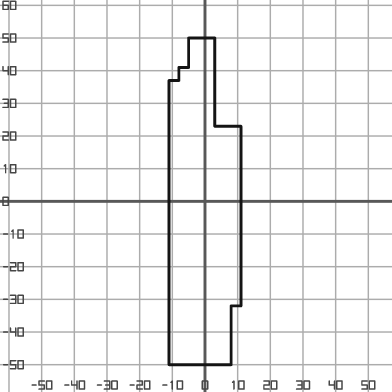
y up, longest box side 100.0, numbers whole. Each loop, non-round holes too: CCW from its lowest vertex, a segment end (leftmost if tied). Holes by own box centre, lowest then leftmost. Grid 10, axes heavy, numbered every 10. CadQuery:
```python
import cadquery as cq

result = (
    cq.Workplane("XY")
    .moveTo(-11.0, -50.0)
    .lineTo(8.0, -50.0)
    .lineTo(8.0, -32.0)
    .lineTo(11.0, -32.0)
    .lineTo(11.0, 23.0)
    .lineTo(3.0, 23.0)
    .lineTo(3.0, 50.0)
    .lineTo(-5.0, 50.0)
    .lineTo(-5.0, 41.0)
    .lineTo(-8.0, 41.0)
    .lineTo(-8.0, 37.0)
    .lineTo(-11.0, 37.0)
    .close()
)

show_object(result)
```